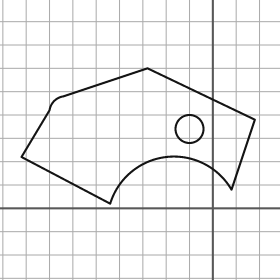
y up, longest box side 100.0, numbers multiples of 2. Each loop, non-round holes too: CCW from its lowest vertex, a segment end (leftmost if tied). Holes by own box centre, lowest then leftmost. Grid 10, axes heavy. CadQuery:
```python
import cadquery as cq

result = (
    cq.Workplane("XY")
    .moveTo(-44.0, 2.0)
    .threePointArc((-20.0, 22.0), (8.0, 8.0))
    .lineTo(18.0, 38.0)
    .lineTo(-28.0, 60.0)
    .lineTo(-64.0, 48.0)
    .threePointArc((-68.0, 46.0), (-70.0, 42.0))
    .lineTo(-82.0, 22.0)
    .close()
    .moveTo(-10.0, 34.0)
    .circle(6.0)
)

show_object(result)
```